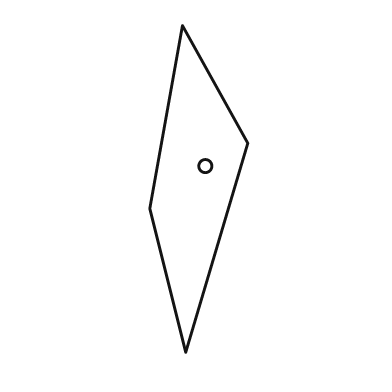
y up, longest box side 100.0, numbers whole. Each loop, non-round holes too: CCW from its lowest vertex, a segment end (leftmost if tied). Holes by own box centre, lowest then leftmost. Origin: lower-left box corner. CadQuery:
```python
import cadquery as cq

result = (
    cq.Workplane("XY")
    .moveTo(11.0, 0.0)
    .lineTo(30.0, 64.0)
    .lineTo(10.0, 100.0)
    .lineTo(0.0, 44.0)
    .close()
    .moveTo(17.0, 57.0)
    .circle(2.0)
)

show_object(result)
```